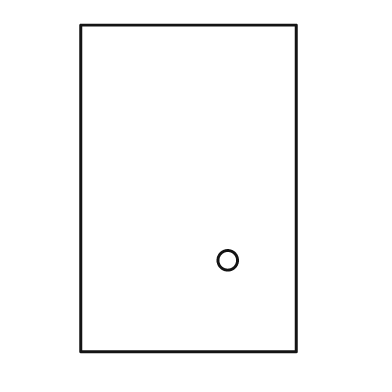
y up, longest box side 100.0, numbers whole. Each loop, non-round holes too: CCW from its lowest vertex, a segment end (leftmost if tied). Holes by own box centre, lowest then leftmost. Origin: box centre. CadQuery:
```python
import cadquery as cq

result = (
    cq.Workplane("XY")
    .moveTo(-33.0, -50.0)
    .lineTo(33.0, -50.0)
    .lineTo(33.0, 50.0)
    .lineTo(-33.0, 50.0)
    .close()
    .moveTo(12.0, -22.0)
    .circle(3.0)
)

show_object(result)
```